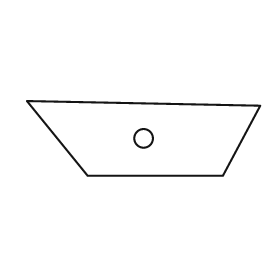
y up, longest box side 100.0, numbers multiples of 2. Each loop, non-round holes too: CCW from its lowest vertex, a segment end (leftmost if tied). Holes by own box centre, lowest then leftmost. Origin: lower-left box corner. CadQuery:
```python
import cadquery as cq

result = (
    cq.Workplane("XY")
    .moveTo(26.0, 0.0)
    .lineTo(84.0, 0.0)
    .lineTo(100.0, 30.0)
    .lineTo(0.0, 32.0)
    .close()
    .moveTo(50.0, 16.0)
    .circle(4.0)
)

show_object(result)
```